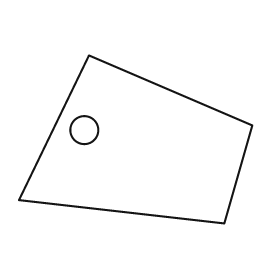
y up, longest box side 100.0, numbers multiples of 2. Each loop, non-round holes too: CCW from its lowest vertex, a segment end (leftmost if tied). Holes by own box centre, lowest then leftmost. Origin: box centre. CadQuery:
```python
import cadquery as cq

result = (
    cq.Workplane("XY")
    .moveTo(38.0, -36.0)
    .lineTo(50.0, 6.0)
    .lineTo(-20.0, 36.0)
    .lineTo(-50.0, -26.0)
    .close()
    .moveTo(-22.0, 4.0)
    .circle(6.0)
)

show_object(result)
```